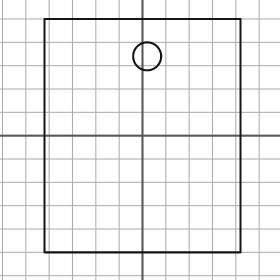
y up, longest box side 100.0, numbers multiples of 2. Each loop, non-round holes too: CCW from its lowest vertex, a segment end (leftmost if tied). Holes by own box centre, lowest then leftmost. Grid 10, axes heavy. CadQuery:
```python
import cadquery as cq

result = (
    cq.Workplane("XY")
    .moveTo(-42.0, -50.0)
    .lineTo(42.0, -50.0)
    .lineTo(42.0, 50.0)
    .lineTo(-42.0, 50.0)
    .close()
    .moveTo(2.0, 34.0)
    .circle(6.0)
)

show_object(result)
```